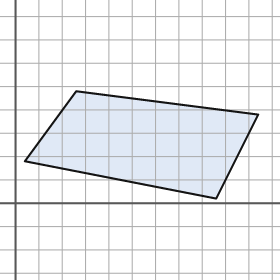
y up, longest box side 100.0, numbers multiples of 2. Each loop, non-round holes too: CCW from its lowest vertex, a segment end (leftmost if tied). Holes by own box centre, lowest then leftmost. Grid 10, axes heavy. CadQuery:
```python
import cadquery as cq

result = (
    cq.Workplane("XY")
    .moveTo(86.0, 2.0)
    .lineTo(104.0, 38.0)
    .lineTo(26.0, 48.0)
    .lineTo(4.0, 18.0)
    .close()
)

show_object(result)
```